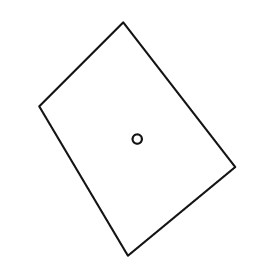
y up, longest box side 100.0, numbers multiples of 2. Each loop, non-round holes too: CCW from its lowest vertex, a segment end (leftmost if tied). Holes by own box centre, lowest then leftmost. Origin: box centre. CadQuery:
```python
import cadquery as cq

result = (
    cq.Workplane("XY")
    .moveTo(-4.0, -50.0)
    .lineTo(42.0, -12.0)
    .lineTo(-6.0, 50.0)
    .lineTo(-42.0, 14.0)
    .close()
    .moveTo(0.0, 0.0)
    .circle(2.0)
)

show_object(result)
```